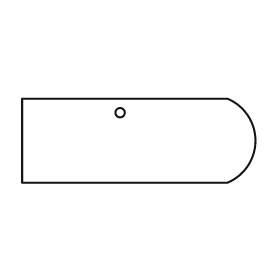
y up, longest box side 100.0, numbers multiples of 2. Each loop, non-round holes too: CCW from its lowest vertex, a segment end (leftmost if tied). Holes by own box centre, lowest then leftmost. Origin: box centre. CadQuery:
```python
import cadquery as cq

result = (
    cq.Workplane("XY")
    .moveTo(-50.0, -18.0)
    .lineTo(38.0, -18.0)
    .threePointArc((50.0, 0.0), (38.0, 18.0))
    .lineTo(-50.0, 18.0)
    .close()
    .moveTo(-8.0, 12.0)
    .circle(2.0)
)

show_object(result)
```